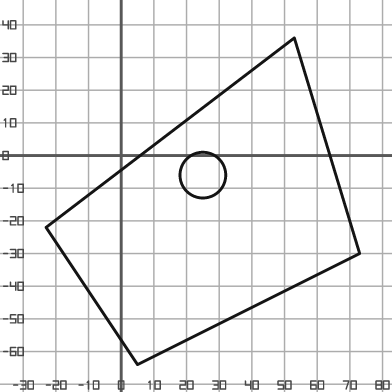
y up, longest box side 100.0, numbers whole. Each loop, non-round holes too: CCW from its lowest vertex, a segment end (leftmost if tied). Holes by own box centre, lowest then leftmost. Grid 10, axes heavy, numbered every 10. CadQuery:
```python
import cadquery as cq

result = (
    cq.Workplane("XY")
    .moveTo(5.0, -64.0)
    .lineTo(73.0, -30.0)
    .lineTo(53.0, 36.0)
    .lineTo(-23.0, -22.0)
    .close()
    .moveTo(25.0, -6.0)
    .circle(7.0)
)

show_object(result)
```